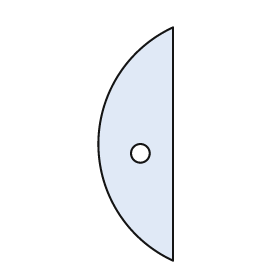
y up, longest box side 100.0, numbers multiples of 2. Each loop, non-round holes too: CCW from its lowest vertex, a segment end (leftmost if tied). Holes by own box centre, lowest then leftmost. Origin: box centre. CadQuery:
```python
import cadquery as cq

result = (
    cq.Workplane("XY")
    .moveTo(16.0, -50.0)
    .lineTo(16.0, 50.0)
    .threePointArc((-16.0, 0.0), (16.0, -50.0))
    .close()
    .moveTo(2.0, -4.0)
    .circle(4.0)
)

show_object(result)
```